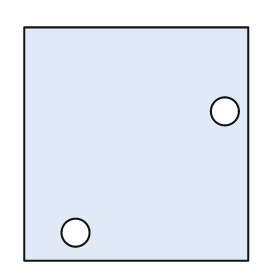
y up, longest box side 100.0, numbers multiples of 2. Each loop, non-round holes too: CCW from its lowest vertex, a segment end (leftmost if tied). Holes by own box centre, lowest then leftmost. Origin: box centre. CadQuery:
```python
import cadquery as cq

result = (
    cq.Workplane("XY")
    .moveTo(-48.0, -50.0)
    .lineTo(48.0, -50.0)
    .lineTo(48.0, 50.0)
    .lineTo(-48.0, 50.0)
    .close()
    .moveTo(-26.0, -38.0)
    .circle(6.0)
    .moveTo(38.0, 14.0)
    .circle(6.0)
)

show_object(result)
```